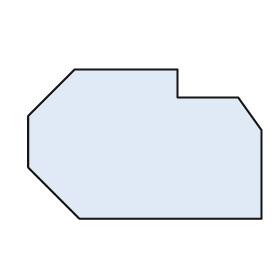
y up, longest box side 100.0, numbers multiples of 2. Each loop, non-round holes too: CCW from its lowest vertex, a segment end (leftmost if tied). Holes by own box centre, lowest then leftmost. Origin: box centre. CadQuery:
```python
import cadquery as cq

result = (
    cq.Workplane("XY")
    .moveTo(-28.0, -32.0)
    .lineTo(50.0, -32.0)
    .lineTo(50.0, 6.0)
    .lineTo(40.0, 20.0)
    .lineTo(14.0, 20.0)
    .lineTo(14.0, 32.0)
    .lineTo(-30.0, 32.0)
    .lineTo(-50.0, 12.0)
    .lineTo(-50.0, -10.0)
    .close()
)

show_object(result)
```